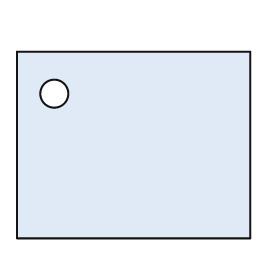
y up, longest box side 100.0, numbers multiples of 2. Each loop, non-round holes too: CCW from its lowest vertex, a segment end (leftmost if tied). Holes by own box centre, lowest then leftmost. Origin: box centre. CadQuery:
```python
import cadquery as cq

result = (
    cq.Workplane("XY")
    .moveTo(-50.0, -40.0)
    .lineTo(50.0, -40.0)
    .lineTo(50.0, 40.0)
    .lineTo(-50.0, 40.0)
    .close()
    .moveTo(-34.0, 22.0)
    .circle(6.0)
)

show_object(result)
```